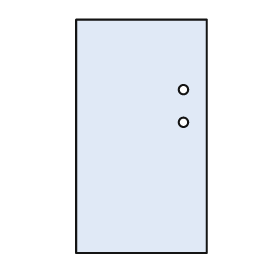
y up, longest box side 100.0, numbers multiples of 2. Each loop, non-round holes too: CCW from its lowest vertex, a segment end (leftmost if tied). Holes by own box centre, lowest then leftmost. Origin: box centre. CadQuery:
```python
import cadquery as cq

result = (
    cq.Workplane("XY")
    .moveTo(-28.0, -50.0)
    .lineTo(28.0, -50.0)
    .lineTo(28.0, 50.0)
    .lineTo(-28.0, 50.0)
    .close()
    .moveTo(18.0, 6.0)
    .circle(2.0)
    .moveTo(18.0, 20.0)
    .circle(2.0)
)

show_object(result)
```